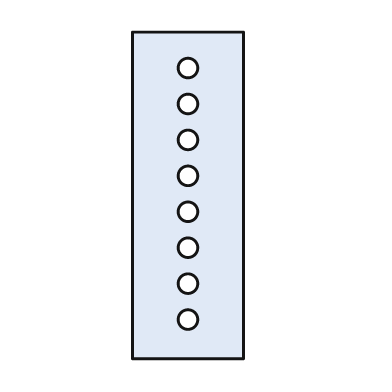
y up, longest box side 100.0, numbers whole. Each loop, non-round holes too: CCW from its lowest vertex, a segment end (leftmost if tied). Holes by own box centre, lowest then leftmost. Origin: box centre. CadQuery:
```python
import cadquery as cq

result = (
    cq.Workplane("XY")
    .moveTo(-17.0, -50.0)
    .lineTo(17.0, -50.0)
    .lineTo(17.0, 50.0)
    .lineTo(-17.0, 50.0)
    .close()
    .moveTo(0.0, -38.0)
    .circle(3.0)
    .moveTo(0.0, -27.0)
    .circle(3.0)
    .moveTo(0.0, -16.0)
    .circle(3.0)
    .moveTo(0.0, -5.0)
    .circle(3.0)
    .moveTo(0.0, 6.0)
    .circle(3.0)
    .moveTo(0.0, 17.0)
    .circle(3.0)
    .moveTo(0.0, 28.0)
    .circle(3.0)
    .moveTo(0.0, 39.0)
    .circle(3.0)
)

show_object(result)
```